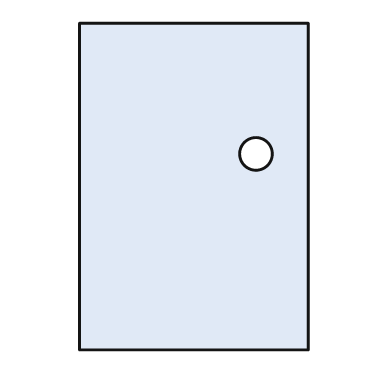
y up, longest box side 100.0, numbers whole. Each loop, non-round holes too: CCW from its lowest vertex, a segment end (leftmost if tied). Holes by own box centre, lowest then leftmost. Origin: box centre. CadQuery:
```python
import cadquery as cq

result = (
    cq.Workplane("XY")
    .moveTo(-35.0, -50.0)
    .lineTo(35.0, -50.0)
    .lineTo(35.0, 50.0)
    .lineTo(-35.0, 50.0)
    .close()
    .moveTo(19.0, 10.0)
    .circle(5.0)
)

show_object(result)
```